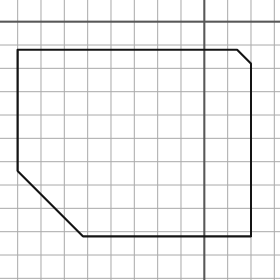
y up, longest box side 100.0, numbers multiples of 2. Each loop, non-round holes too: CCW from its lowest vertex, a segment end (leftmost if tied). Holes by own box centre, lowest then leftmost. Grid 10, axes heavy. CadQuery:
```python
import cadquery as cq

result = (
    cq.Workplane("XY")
    .moveTo(-52.0, -92.0)
    .lineTo(20.0, -92.0)
    .lineTo(20.0, -18.0)
    .lineTo(14.0, -12.0)
    .lineTo(-80.0, -12.0)
    .lineTo(-80.0, -64.0)
    .close()
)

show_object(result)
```